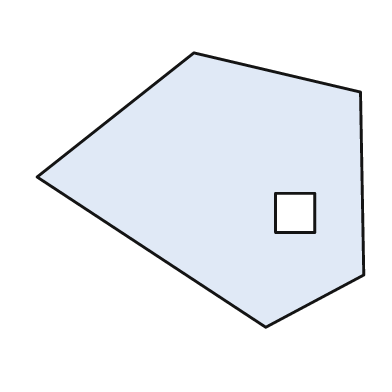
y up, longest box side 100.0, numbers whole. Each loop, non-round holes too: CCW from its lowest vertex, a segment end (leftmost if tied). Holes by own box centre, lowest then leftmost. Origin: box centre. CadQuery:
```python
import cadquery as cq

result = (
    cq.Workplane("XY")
    .moveTo(20.0, -42.0)
    .lineTo(50.0, -26.0)
    .lineTo(49.0, 30.0)
    .lineTo(-2.0, 42.0)
    .lineTo(-50.0, 4.0)
    .close()
    .moveTo(23.0, -13.0)
    .lineTo(35.0, -13.0)
    .lineTo(35.0, -1.0)
    .lineTo(23.0, -1.0)
    .close()
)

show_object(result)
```